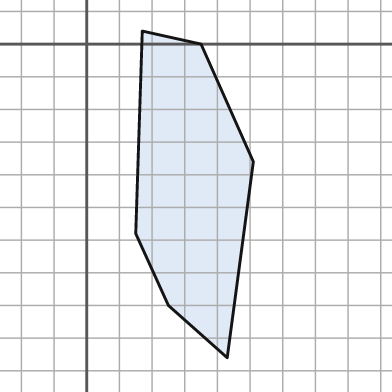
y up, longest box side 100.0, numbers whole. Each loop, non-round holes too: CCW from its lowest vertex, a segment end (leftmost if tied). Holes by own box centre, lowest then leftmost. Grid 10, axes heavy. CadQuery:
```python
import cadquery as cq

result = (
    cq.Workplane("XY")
    .moveTo(43.0, -96.0)
    .lineTo(51.0, -36.0)
    .lineTo(35.0, 0.0)
    .lineTo(17.0, 4.0)
    .lineTo(15.0, -58.0)
    .lineTo(25.0, -80.0)
    .close()
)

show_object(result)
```